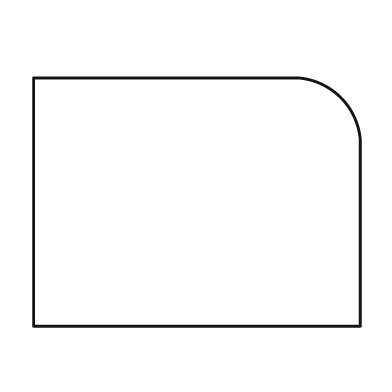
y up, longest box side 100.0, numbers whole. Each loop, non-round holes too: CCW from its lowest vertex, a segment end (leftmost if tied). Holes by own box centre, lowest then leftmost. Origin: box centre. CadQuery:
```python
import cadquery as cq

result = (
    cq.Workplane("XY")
    .moveTo(-50.0, -38.0)
    .lineTo(50.0, -38.0)
    .lineTo(50.0, 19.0)
    .threePointArc((44.0, 32.0), (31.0, 38.0))
    .lineTo(-50.0, 38.0)
    .close()
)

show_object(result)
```